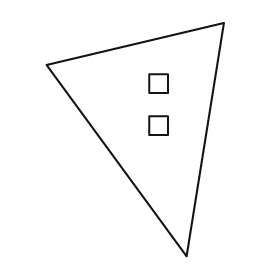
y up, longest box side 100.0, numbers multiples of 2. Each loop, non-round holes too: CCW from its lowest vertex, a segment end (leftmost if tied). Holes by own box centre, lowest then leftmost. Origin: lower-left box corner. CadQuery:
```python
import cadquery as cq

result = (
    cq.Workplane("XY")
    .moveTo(60.0, 0.0)
    .lineTo(76.0, 100.0)
    .lineTo(0.0, 82.0)
    .close()
    .moveTo(44.0, 52.0)
    .lineTo(52.0, 52.0)
    .lineTo(52.0, 60.0)
    .lineTo(44.0, 60.0)
    .close()
    .moveTo(44.0, 70.0)
    .lineTo(52.0, 70.0)
    .lineTo(52.0, 78.0)
    .lineTo(44.0, 78.0)
    .close()
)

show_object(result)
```